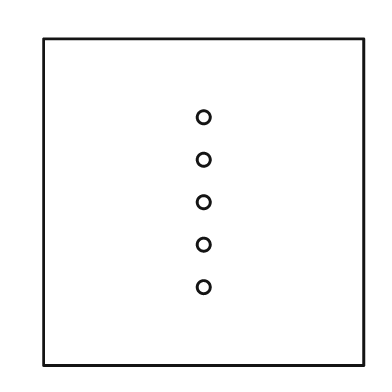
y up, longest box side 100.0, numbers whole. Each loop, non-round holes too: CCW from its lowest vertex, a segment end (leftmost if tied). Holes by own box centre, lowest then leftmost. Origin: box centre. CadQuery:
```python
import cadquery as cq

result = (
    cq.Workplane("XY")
    .moveTo(-49.0, -50.0)
    .lineTo(49.0, -50.0)
    .lineTo(49.0, 50.0)
    .lineTo(-49.0, 50.0)
    .close()
    .moveTo(0.0, -26.0)
    .circle(2.0)
    .moveTo(0.0, -13.0)
    .circle(2.0)
    .moveTo(0.0, 0.0)
    .circle(2.0)
    .moveTo(0.0, 13.0)
    .circle(2.0)
    .moveTo(0.0, 26.0)
    .circle(2.0)
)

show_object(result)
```